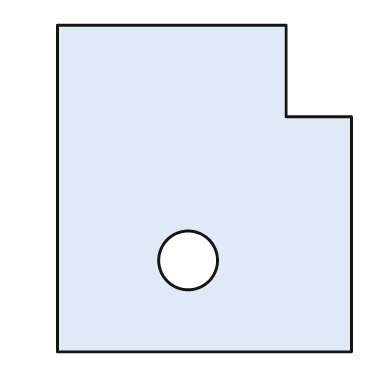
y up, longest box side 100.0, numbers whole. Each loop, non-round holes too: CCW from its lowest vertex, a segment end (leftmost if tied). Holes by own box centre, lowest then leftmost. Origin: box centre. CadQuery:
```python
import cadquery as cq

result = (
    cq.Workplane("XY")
    .moveTo(-45.0, -50.0)
    .lineTo(45.0, -50.0)
    .lineTo(45.0, 22.0)
    .lineTo(25.0, 22.0)
    .lineTo(25.0, 50.0)
    .lineTo(-45.0, 50.0)
    .close()
    .moveTo(-5.0, -22.0)
    .circle(9.0)
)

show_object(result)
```